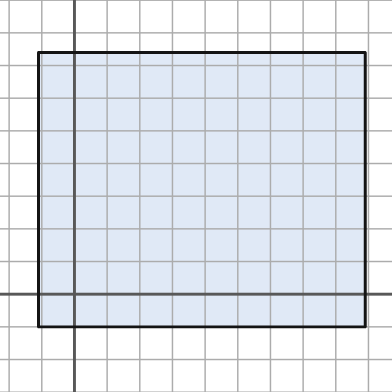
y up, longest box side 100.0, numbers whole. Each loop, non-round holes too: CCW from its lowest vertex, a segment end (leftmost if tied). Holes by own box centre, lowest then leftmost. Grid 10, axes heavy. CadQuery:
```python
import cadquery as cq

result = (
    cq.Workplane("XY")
    .moveTo(-11.0, -10.0)
    .lineTo(89.0, -10.0)
    .lineTo(89.0, 74.0)
    .lineTo(-11.0, 74.0)
    .close()
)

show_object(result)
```